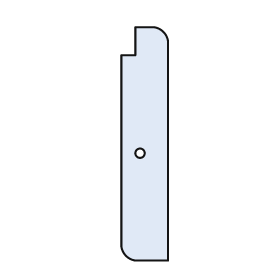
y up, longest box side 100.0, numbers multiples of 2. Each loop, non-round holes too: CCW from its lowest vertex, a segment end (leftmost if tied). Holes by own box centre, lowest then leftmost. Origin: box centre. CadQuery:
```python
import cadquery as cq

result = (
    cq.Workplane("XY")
    .moveTo(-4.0, -50.0)
    .lineTo(10.0, -50.0)
    .lineTo(10.0, 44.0)
    .threePointArc((8.0, 48.0), (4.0, 50.0))
    .lineTo(-4.0, 50.0)
    .lineTo(-4.0, 38.0)
    .lineTo(-10.0, 38.0)
    .lineTo(-10.0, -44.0)
    .threePointArc((-8.0, -48.0), (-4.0, -50.0))
    .close()
    .moveTo(-2.0, -4.0)
    .circle(2.0)
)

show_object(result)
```